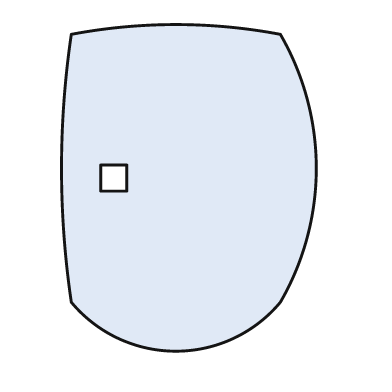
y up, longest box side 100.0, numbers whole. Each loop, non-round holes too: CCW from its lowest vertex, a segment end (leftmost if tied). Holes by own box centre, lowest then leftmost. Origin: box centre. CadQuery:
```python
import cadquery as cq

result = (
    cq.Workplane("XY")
    .moveTo(-36.0, -35.0)
    .threePointArc((-4.0, -50.0), (28.0, -35.0))
    .threePointArc((39.0, 6.0), (28.0, 47.0))
    .threePointArc((-4.0, 50.0), (-36.0, 47.0))
    .threePointArc((-39.0, 6.0), (-36.0, -35.0))
    .close()
    .moveTo(-27.0, -1.0)
    .lineTo(-19.0, -1.0)
    .lineTo(-19.0, 7.0)
    .lineTo(-27.0, 7.0)
    .close()
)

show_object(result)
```